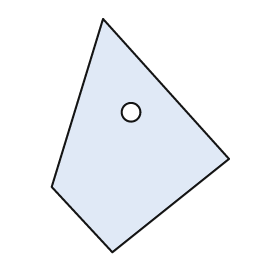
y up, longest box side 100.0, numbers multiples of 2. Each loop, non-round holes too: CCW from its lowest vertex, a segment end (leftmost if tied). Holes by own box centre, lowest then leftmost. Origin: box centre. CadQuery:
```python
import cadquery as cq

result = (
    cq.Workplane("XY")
    .moveTo(-12.0, -50.0)
    .lineTo(38.0, -10.0)
    .lineTo(-16.0, 50.0)
    .lineTo(-38.0, -22.0)
    .close()
    .moveTo(-4.0, 10.0)
    .circle(4.0)
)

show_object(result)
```